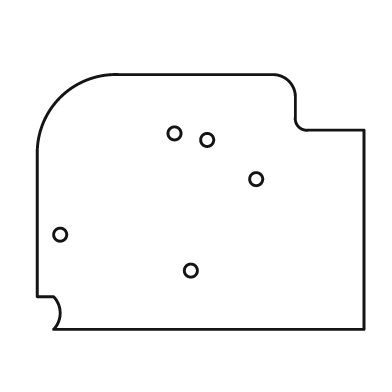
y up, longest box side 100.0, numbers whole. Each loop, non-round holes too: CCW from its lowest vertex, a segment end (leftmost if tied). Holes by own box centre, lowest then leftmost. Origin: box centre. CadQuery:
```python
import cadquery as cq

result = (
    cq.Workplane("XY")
    .moveTo(-45.0, -39.0)
    .lineTo(50.0, -39.0)
    .lineTo(50.0, 22.0)
    .lineTo(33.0, 22.0)
    .threePointArc((30.0, 23.0), (29.0, 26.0))
    .lineTo(29.0, 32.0)
    .threePointArc((27.0, 37.0), (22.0, 39.0))
    .lineTo(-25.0, 39.0)
    .threePointArc((-43.0, 32.0), (-50.0, 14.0))
    .lineTo(-50.0, -29.0)
    .lineTo(-45.0, -29.0)
    .threePointArc((-43.0, -34.0), (-45.0, -39.0))
    .close()
    .moveTo(-3.0, -21.0)
    .circle(2.0)
    .moveTo(-43.0, -10.0)
    .circle(2.0)
    .moveTo(17.0, 7.0)
    .circle(2.0)
    .moveTo(2.0, 19.0)
    .circle(2.0)
    .moveTo(-8.0, 21.0)
    .circle(2.0)
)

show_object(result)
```